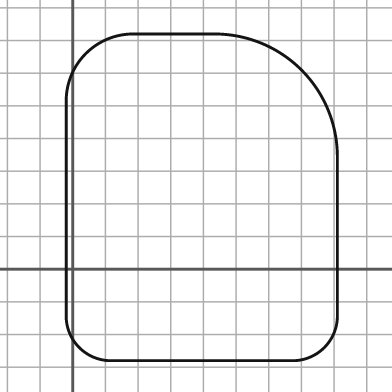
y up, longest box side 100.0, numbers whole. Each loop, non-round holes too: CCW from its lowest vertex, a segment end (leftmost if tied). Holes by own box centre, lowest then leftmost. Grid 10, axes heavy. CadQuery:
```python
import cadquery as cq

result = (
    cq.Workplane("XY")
    .moveTo(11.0, -28.0)
    .lineTo(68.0, -28.0)
    .threePointArc((77.0, -24.0), (81.0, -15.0))
    .lineTo(81.0, 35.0)
    .threePointArc((70.0, 61.0), (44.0, 72.0))
    .lineTo(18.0, 72.0)
    .threePointArc((4.0, 66.0), (-2.0, 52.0))
    .lineTo(-2.0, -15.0)
    .threePointArc((2.0, -24.0), (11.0, -28.0))
    .close()
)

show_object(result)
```